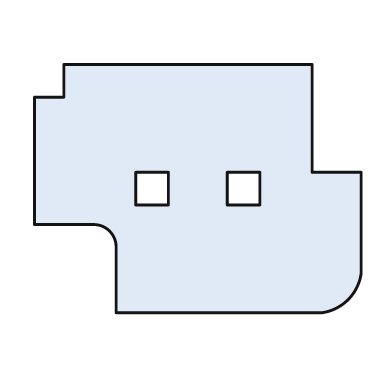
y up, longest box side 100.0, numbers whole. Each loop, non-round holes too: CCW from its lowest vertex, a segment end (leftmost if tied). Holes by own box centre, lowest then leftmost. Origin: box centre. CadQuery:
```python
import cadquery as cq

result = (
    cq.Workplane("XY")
    .moveTo(-25.0, -38.0)
    .lineTo(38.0, -38.0)
    .threePointArc((46.0, -34.0), (50.0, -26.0))
    .lineTo(50.0, 5.0)
    .lineTo(35.0, 5.0)
    .lineTo(35.0, 38.0)
    .lineTo(-41.0, 38.0)
    .lineTo(-41.0, 28.0)
    .lineTo(-50.0, 28.0)
    .lineTo(-50.0, -11.0)
    .lineTo(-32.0, -11.0)
    .threePointArc((-27.0, -13.0), (-25.0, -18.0))
    .close()
    .moveTo(-19.0, -5.0)
    .lineTo(-9.0, -5.0)
    .lineTo(-9.0, 5.0)
    .lineTo(-19.0, 5.0)
    .close()
    .moveTo(9.0, -5.0)
    .lineTo(19.0, -5.0)
    .lineTo(19.0, 5.0)
    .lineTo(9.0, 5.0)
    .close()
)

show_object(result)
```